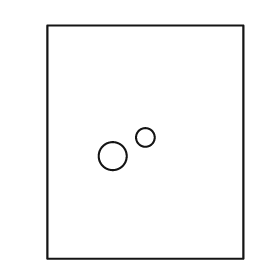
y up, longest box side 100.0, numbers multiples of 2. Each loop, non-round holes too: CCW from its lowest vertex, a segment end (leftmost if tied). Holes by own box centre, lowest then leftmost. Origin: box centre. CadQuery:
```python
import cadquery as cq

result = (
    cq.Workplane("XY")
    .moveTo(-42.0, -50.0)
    .lineTo(42.0, -50.0)
    .lineTo(42.0, 50.0)
    .lineTo(-42.0, 50.0)
    .close()
    .moveTo(-14.0, -6.0)
    .circle(6.0)
    .moveTo(0.0, 2.0)
    .circle(4.0)
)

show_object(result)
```